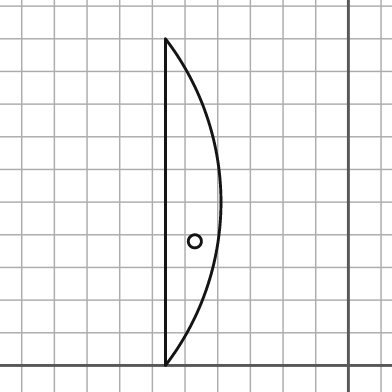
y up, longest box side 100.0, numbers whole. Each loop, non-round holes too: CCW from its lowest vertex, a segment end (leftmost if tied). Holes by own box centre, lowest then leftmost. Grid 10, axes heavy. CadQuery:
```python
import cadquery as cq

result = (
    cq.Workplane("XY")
    .moveTo(-56.0, 0.0)
    .threePointArc((-39.0, 50.0), (-56.0, 100.0))
    .close()
    .moveTo(-47.0, 38.0)
    .circle(2.0)
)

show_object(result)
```